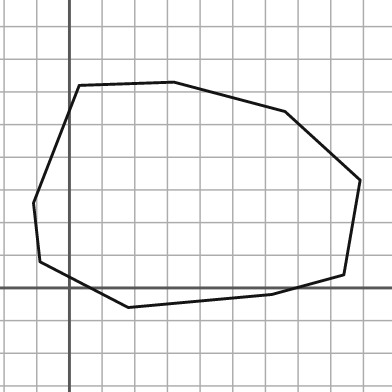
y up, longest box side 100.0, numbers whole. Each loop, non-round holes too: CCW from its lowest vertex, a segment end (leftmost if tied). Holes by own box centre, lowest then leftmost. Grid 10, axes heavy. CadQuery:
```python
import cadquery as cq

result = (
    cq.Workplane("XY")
    .moveTo(18.0, -6.0)
    .lineTo(62.0, -2.0)
    .lineTo(84.0, 4.0)
    .lineTo(89.0, 33.0)
    .lineTo(66.0, 54.0)
    .lineTo(32.0, 63.0)
    .lineTo(3.0, 62.0)
    .lineTo(-11.0, 26.0)
    .lineTo(-9.0, 8.0)
    .close()
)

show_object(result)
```